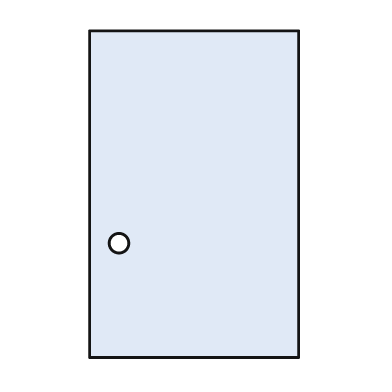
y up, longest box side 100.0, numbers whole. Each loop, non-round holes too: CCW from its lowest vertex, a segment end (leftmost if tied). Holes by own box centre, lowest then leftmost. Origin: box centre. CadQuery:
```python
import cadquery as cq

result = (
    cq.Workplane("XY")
    .moveTo(-32.0, -50.0)
    .lineTo(32.0, -50.0)
    .lineTo(32.0, 50.0)
    .lineTo(-32.0, 50.0)
    .close()
    .moveTo(-23.0, -15.0)
    .circle(3.0)
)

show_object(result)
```